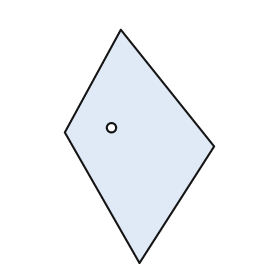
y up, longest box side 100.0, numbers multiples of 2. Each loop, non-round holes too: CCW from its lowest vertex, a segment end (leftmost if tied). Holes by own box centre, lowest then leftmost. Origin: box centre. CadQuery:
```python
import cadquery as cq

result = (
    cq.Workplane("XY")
    .moveTo(0.0, -50.0)
    .lineTo(32.0, 0.0)
    .lineTo(-8.0, 50.0)
    .lineTo(-32.0, 6.0)
    .close()
    .moveTo(-12.0, 8.0)
    .circle(2.0)
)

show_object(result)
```